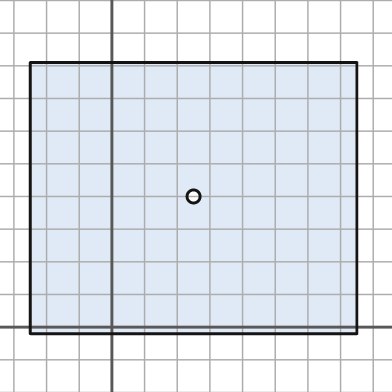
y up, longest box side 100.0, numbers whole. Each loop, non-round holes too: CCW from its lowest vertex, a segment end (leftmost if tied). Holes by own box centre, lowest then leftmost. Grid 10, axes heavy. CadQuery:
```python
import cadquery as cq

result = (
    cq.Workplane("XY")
    .moveTo(-25.0, -2.0)
    .lineTo(75.0, -2.0)
    .lineTo(75.0, 81.0)
    .lineTo(-25.0, 81.0)
    .close()
    .moveTo(25.0, 40.0)
    .circle(2.0)
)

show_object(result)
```